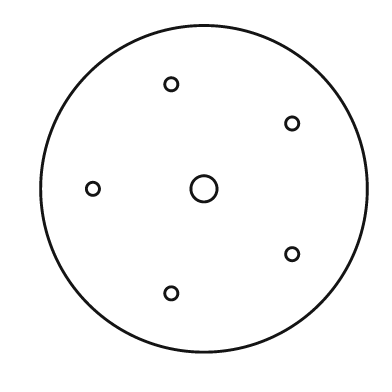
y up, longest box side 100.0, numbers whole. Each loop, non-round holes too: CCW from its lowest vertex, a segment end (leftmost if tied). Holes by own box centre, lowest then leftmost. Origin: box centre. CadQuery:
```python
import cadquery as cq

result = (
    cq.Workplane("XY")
    .moveTo(0.0, 0.0)
    .circle(50.0)
    .moveTo(-10.0, -32.0)
    .circle(2.0)
    .moveTo(27.0, -20.0)
    .circle(2.0)
    .moveTo(-34.0, 0.0)
    .circle(2.0)
    .moveTo(0.0, 0.0)
    .circle(4.0)
    .moveTo(27.0, 20.0)
    .circle(2.0)
    .moveTo(-10.0, 32.0)
    .circle(2.0)
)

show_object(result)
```